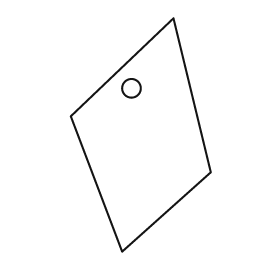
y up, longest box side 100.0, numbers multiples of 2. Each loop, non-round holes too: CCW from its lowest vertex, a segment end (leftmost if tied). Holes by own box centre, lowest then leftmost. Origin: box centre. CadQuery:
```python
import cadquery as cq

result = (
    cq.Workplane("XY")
    .moveTo(-8.0, -50.0)
    .lineTo(30.0, -16.0)
    .lineTo(14.0, 50.0)
    .lineTo(-30.0, 8.0)
    .close()
    .moveTo(-4.0, 20.0)
    .circle(4.0)
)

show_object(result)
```